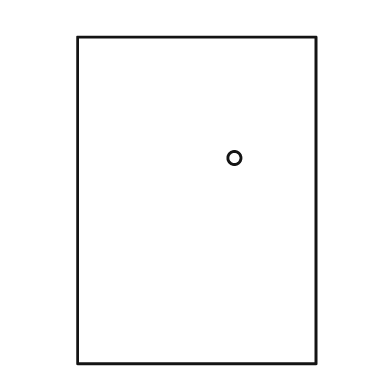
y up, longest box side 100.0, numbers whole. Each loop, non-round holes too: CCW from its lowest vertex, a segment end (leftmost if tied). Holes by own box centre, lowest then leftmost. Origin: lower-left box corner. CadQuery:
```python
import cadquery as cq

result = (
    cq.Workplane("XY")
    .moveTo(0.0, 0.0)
    .lineTo(73.0, 0.0)
    .lineTo(73.0, 100.0)
    .lineTo(0.0, 100.0)
    .close()
    .moveTo(48.0, 63.0)
    .circle(2.0)
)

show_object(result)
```